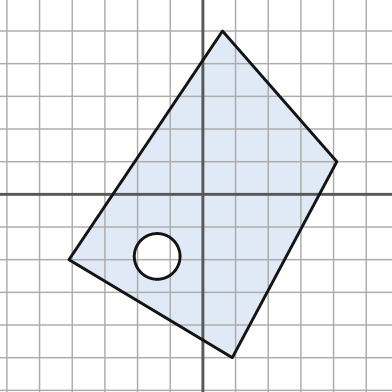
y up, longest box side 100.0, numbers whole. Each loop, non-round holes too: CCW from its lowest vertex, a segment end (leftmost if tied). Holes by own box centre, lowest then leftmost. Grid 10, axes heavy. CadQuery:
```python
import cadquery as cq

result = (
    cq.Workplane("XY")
    .moveTo(9.0, -50.0)
    .lineTo(41.0, 10.0)
    .lineTo(6.0, 50.0)
    .lineTo(-41.0, -20.0)
    .close()
    .moveTo(-14.0, -19.0)
    .circle(7.0)
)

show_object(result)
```